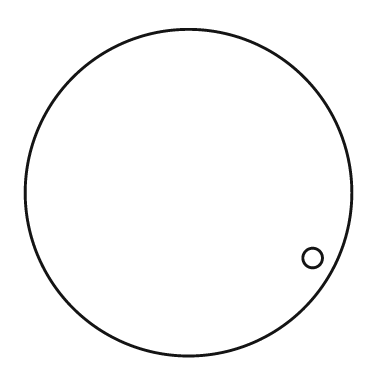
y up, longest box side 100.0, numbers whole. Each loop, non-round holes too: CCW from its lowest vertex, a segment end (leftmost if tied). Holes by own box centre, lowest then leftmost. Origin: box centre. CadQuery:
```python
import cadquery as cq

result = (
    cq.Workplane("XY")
    .moveTo(0.0, 0.0)
    .circle(50.0)
    .moveTo(38.0, -20.0)
    .circle(3.0)
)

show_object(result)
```